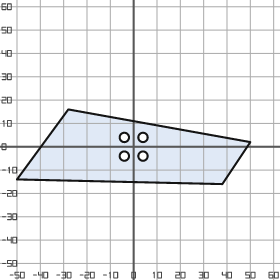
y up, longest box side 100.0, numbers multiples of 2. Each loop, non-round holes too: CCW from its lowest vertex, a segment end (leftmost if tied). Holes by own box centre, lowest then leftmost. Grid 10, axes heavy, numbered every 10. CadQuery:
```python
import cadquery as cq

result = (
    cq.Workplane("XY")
    .moveTo(38.0, -16.0)
    .lineTo(50.0, 2.0)
    .lineTo(-28.0, 16.0)
    .lineTo(-50.0, -14.0)
    .close()
    .moveTo(-4.0, -4.0)
    .circle(2.0)
    .moveTo(4.0, -4.0)
    .circle(2.0)
    .moveTo(-4.0, 4.0)
    .circle(2.0)
    .moveTo(4.0, 4.0)
    .circle(2.0)
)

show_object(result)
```